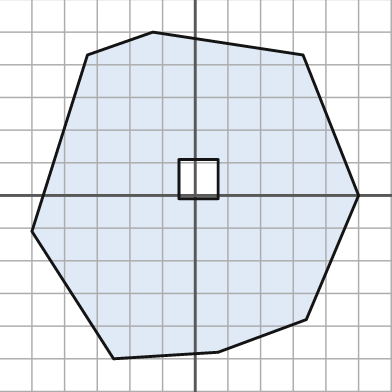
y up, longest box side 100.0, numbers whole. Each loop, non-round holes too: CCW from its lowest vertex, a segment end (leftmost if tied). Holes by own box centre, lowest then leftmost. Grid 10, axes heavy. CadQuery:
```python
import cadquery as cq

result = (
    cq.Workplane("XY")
    .moveTo(-25.0, -50.0)
    .lineTo(7.0, -48.0)
    .lineTo(34.0, -38.0)
    .lineTo(50.0, 0.0)
    .lineTo(33.0, 43.0)
    .lineTo(-13.0, 50.0)
    .lineTo(-33.0, 43.0)
    .lineTo(-50.0, -11.0)
    .close()
    .moveTo(-5.0, -1.0)
    .lineTo(7.0, -1.0)
    .lineTo(7.0, 11.0)
    .lineTo(-5.0, 11.0)
    .close()
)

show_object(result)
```